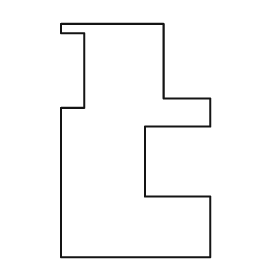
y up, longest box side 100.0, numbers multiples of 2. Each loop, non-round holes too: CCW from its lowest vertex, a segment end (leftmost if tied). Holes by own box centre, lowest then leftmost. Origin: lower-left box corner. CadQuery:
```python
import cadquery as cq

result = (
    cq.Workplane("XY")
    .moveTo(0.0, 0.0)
    .lineTo(64.0, 0.0)
    .lineTo(64.0, 26.0)
    .lineTo(36.0, 26.0)
    .lineTo(36.0, 56.0)
    .lineTo(64.0, 56.0)
    .lineTo(64.0, 68.0)
    .lineTo(44.0, 68.0)
    .lineTo(44.0, 100.0)
    .lineTo(0.0, 100.0)
    .lineTo(0.0, 96.0)
    .lineTo(10.0, 96.0)
    .lineTo(10.0, 64.0)
    .lineTo(0.0, 64.0)
    .close()
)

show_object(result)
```